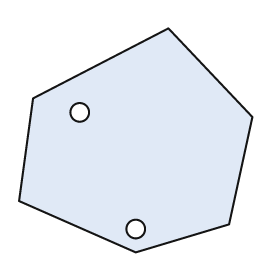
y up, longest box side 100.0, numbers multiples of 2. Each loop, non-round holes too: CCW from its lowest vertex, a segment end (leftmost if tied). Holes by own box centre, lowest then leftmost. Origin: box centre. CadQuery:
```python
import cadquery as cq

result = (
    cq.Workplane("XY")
    .moveTo(0.0, -48.0)
    .lineTo(40.0, -36.0)
    .lineTo(50.0, 10.0)
    .lineTo(14.0, 48.0)
    .lineTo(-44.0, 18.0)
    .lineTo(-50.0, -26.0)
    .close()
    .moveTo(0.0, -38.0)
    .circle(4.0)
    .moveTo(-24.0, 12.0)
    .circle(4.0)
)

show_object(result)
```